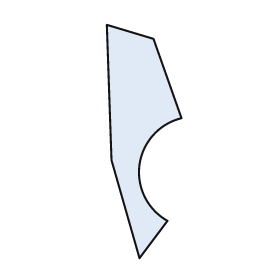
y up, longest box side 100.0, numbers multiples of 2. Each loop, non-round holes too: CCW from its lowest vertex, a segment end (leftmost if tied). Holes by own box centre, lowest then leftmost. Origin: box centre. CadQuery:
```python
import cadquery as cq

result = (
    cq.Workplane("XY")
    .moveTo(-2.0, -50.0)
    .lineTo(10.0, -34.0)
    .threePointArc((-2.0, -10.0), (16.0, 10.0))
    .lineTo(4.0, 44.0)
    .lineTo(-16.0, 50.0)
    .lineTo(-14.0, -8.0)
    .close()
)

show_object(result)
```